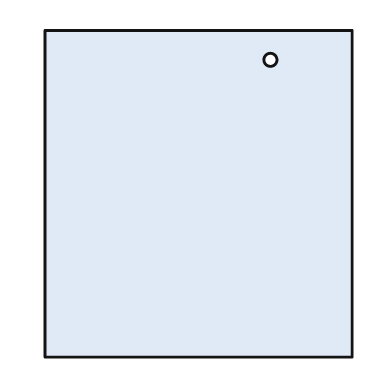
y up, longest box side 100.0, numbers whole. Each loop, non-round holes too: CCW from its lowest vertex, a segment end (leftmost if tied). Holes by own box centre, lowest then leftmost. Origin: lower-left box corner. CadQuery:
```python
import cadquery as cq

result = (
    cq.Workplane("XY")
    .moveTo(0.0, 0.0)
    .lineTo(94.0, 0.0)
    .lineTo(94.0, 100.0)
    .lineTo(0.0, 100.0)
    .close()
    .moveTo(69.0, 91.0)
    .circle(2.0)
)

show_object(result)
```